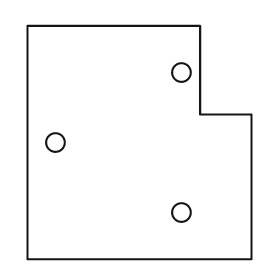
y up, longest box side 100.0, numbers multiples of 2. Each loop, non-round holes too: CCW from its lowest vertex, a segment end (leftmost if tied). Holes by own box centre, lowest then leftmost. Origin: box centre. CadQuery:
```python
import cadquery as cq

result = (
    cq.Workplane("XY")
    .moveTo(-48.0, -50.0)
    .lineTo(48.0, -50.0)
    .lineTo(48.0, 12.0)
    .lineTo(26.0, 12.0)
    .lineTo(26.0, 50.0)
    .lineTo(-48.0, 50.0)
    .close()
    .moveTo(18.0, -30.0)
    .circle(4.0)
    .moveTo(-36.0, 0.0)
    .circle(4.0)
    .moveTo(18.0, 30.0)
    .circle(4.0)
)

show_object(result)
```